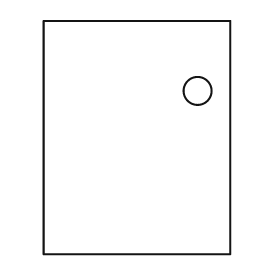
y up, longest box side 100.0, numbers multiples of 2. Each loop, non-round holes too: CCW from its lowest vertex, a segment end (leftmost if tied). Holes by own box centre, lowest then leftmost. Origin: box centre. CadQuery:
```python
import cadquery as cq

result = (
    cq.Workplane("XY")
    .moveTo(-40.0, -50.0)
    .lineTo(40.0, -50.0)
    .lineTo(40.0, 50.0)
    .lineTo(-40.0, 50.0)
    .close()
    .moveTo(26.0, 20.0)
    .circle(6.0)
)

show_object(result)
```